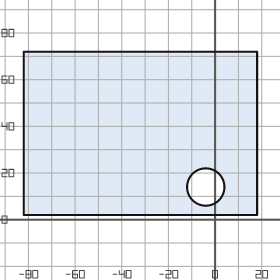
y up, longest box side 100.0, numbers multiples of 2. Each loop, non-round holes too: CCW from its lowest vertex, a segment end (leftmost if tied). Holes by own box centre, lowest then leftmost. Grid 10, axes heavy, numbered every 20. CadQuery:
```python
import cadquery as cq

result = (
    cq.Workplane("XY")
    .moveTo(-82.0, 2.0)
    .lineTo(18.0, 2.0)
    .lineTo(18.0, 72.0)
    .lineTo(-82.0, 72.0)
    .close()
    .moveTo(-4.0, 14.0)
    .circle(8.0)
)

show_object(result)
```